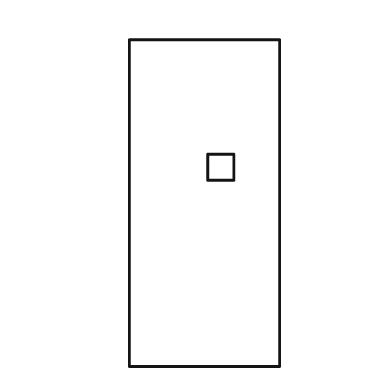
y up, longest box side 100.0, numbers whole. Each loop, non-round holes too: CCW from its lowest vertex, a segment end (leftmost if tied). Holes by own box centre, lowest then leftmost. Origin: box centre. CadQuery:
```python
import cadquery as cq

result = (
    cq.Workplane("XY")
    .moveTo(-23.0, -50.0)
    .lineTo(23.0, -50.0)
    .lineTo(23.0, 50.0)
    .lineTo(-23.0, 50.0)
    .close()
    .moveTo(1.0, 7.0)
    .lineTo(9.0, 7.0)
    .lineTo(9.0, 15.0)
    .lineTo(1.0, 15.0)
    .close()
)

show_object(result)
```